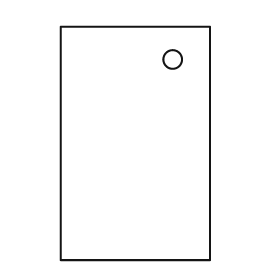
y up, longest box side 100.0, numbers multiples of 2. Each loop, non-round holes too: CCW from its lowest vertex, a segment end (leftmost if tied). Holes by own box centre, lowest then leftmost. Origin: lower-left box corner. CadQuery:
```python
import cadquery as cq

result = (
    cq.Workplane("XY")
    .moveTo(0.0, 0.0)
    .lineTo(64.0, 0.0)
    .lineTo(64.0, 100.0)
    .lineTo(0.0, 100.0)
    .close()
    .moveTo(48.0, 86.0)
    .circle(4.0)
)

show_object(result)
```